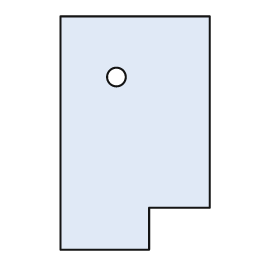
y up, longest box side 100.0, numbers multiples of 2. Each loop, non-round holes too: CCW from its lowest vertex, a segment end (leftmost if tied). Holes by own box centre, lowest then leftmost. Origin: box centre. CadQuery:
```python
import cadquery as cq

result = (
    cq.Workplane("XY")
    .moveTo(-32.0, -50.0)
    .lineTo(6.0, -50.0)
    .lineTo(6.0, -32.0)
    .lineTo(32.0, -32.0)
    .lineTo(32.0, 50.0)
    .lineTo(-32.0, 50.0)
    .close()
    .moveTo(-8.0, 24.0)
    .circle(4.0)
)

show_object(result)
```